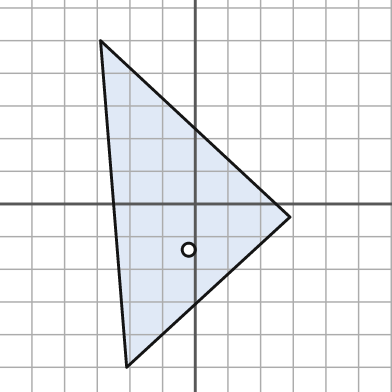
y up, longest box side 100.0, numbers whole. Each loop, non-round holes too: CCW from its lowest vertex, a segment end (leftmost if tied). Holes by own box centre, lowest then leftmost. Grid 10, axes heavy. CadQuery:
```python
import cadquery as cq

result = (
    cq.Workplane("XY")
    .moveTo(-21.0, -50.0)
    .lineTo(29.0, -4.0)
    .lineTo(-29.0, 50.0)
    .close()
    .moveTo(-2.0, -14.0)
    .circle(2.0)
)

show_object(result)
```